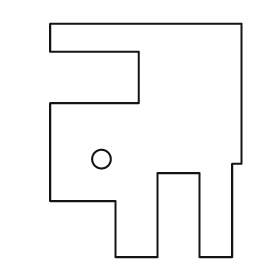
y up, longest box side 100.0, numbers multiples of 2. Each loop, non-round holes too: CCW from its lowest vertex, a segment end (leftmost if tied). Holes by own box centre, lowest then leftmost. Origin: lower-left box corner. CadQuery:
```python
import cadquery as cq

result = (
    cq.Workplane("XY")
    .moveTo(28.0, 0.0)
    .lineTo(46.0, 0.0)
    .lineTo(46.0, 36.0)
    .lineTo(64.0, 36.0)
    .lineTo(64.0, 0.0)
    .lineTo(78.0, 0.0)
    .lineTo(78.0, 40.0)
    .lineTo(82.0, 40.0)
    .lineTo(82.0, 100.0)
    .lineTo(0.0, 100.0)
    .lineTo(0.0, 88.0)
    .lineTo(38.0, 88.0)
    .lineTo(38.0, 66.0)
    .lineTo(0.0, 66.0)
    .lineTo(0.0, 24.0)
    .lineTo(28.0, 24.0)
    .close()
    .moveTo(22.0, 42.0)
    .circle(4.0)
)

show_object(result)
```